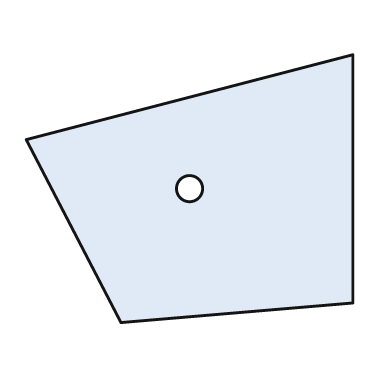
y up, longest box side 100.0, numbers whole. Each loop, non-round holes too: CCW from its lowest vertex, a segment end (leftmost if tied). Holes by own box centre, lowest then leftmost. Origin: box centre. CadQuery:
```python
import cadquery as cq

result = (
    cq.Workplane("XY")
    .moveTo(-21.0, -41.0)
    .lineTo(50.0, -35.0)
    .lineTo(50.0, 41.0)
    .lineTo(-50.0, 15.0)
    .close()
    .moveTo(0.0, 0.0)
    .circle(4.0)
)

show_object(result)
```